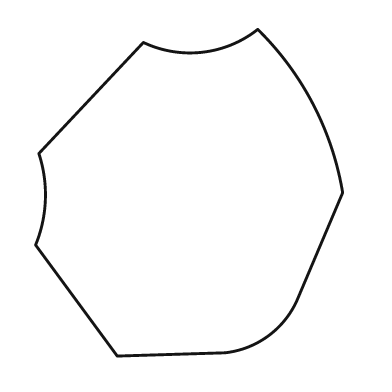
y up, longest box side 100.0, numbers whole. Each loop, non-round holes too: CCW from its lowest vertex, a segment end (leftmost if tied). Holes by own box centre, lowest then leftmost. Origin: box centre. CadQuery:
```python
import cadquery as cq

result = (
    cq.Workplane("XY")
    .moveTo(-22.0, -50.0)
    .lineTo(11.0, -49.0)
    .threePointArc((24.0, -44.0), (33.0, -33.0))
    .lineTo(47.0, 0.0)
    .threePointArc((38.0, 27.0), (21.0, 50.0))
    .threePointArc((4.0, 43.0), (-14.0, 46.0))
    .lineTo(-46.0, 12.0)
    .threePointArc((-44.0, -2.0), (-47.0, -16.0))
    .close()
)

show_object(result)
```